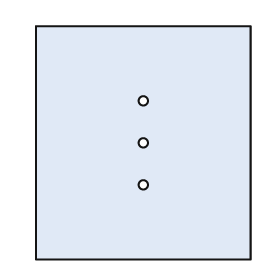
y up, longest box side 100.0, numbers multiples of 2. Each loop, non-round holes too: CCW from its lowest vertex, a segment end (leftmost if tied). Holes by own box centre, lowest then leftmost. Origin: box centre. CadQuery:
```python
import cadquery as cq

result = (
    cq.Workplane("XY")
    .moveTo(-46.0, -50.0)
    .lineTo(46.0, -50.0)
    .lineTo(46.0, 50.0)
    .lineTo(-46.0, 50.0)
    .close()
    .moveTo(0.0, -18.0)
    .circle(2.0)
    .moveTo(0.0, 0.0)
    .circle(2.0)
    .moveTo(0.0, 18.0)
    .circle(2.0)
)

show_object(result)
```